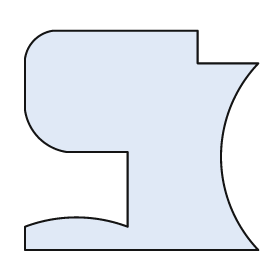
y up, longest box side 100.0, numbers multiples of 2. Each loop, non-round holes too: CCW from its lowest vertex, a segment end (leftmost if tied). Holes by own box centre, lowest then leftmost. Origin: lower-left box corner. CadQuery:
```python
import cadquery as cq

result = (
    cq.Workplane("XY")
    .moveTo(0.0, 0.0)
    .lineTo(100.0, 0.0)
    .threePointArc((84.0, 40.0), (100.0, 80.0))
    .lineTo(74.0, 80.0)
    .lineTo(74.0, 94.0)
    .lineTo(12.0, 94.0)
    .threePointArc((4.0, 90.0), (0.0, 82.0))
    .lineTo(0.0, 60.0)
    .threePointArc((6.0, 48.0), (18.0, 42.0))
    .lineTo(44.0, 42.0)
    .lineTo(44.0, 10.0)
    .threePointArc((22.0, 14.0), (0.0, 10.0))
    .close()
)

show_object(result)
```